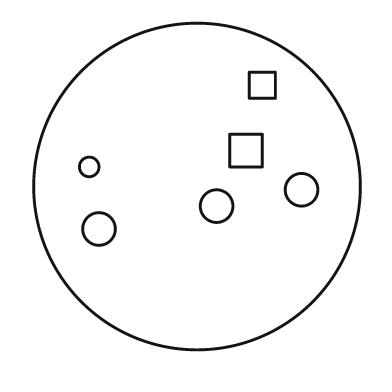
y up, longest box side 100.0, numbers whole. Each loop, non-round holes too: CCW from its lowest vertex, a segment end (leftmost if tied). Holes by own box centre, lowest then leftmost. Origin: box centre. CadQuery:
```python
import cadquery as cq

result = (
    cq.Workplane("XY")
    .moveTo(0.0, 0.0)
    .circle(50.0)
    .moveTo(-30.0, -13.0)
    .circle(5.0)
    .moveTo(6.0, -6.0)
    .circle(5.0)
    .moveTo(32.0, -1.0)
    .circle(5.0)
    .moveTo(-33.0, 6.0)
    .circle(3.0)
    .moveTo(10.0, 6.0)
    .lineTo(20.0, 6.0)
    .lineTo(20.0, 16.0)
    .lineTo(10.0, 16.0)
    .close()
    .moveTo(16.0, 27.0)
    .lineTo(24.0, 27.0)
    .lineTo(24.0, 35.0)
    .lineTo(16.0, 35.0)
    .close()
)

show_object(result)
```